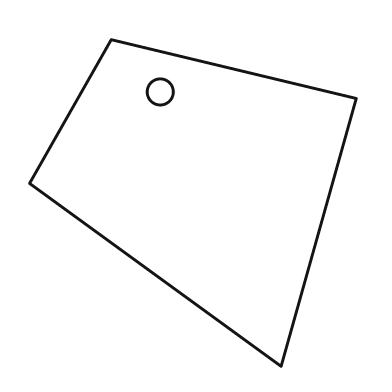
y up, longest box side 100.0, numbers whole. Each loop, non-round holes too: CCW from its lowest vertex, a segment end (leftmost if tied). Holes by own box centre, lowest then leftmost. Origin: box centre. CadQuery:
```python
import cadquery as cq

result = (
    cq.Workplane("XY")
    .moveTo(27.0, -50.0)
    .lineTo(50.0, 32.0)
    .lineTo(-25.0, 50.0)
    .lineTo(-50.0, 6.0)
    .close()
    .moveTo(-10.0, 34.0)
    .circle(4.0)
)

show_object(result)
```